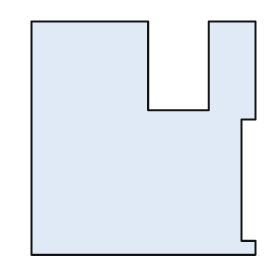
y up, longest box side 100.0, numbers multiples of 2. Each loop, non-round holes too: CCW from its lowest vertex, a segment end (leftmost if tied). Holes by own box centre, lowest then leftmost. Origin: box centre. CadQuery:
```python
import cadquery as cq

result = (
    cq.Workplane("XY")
    .moveTo(-48.0, -50.0)
    .lineTo(48.0, -50.0)
    .lineTo(48.0, -44.0)
    .lineTo(42.0, -44.0)
    .lineTo(42.0, 8.0)
    .lineTo(48.0, 8.0)
    .lineTo(48.0, 50.0)
    .lineTo(28.0, 50.0)
    .lineTo(28.0, 12.0)
    .lineTo(2.0, 12.0)
    .lineTo(2.0, 50.0)
    .lineTo(-48.0, 50.0)
    .close()
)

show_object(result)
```